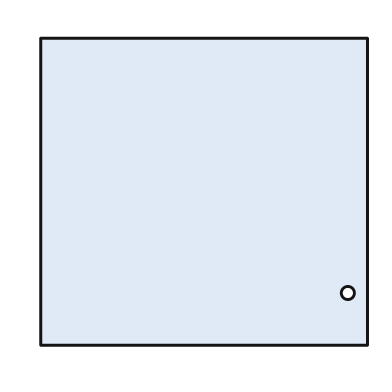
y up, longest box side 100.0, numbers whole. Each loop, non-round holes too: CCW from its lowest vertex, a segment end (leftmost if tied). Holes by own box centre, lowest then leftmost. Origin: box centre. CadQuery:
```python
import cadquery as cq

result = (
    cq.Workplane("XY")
    .moveTo(-50.0, -47.0)
    .lineTo(50.0, -47.0)
    .lineTo(50.0, 47.0)
    .lineTo(-50.0, 47.0)
    .close()
    .moveTo(44.0, -31.0)
    .circle(2.0)
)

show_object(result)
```